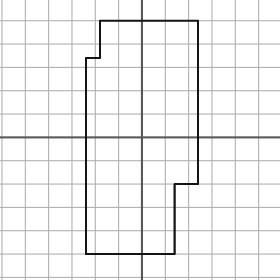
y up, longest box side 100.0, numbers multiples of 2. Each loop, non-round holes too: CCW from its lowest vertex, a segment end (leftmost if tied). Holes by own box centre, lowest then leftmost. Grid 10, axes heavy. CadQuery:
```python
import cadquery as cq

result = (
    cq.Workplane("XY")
    .moveTo(-24.0, -50.0)
    .lineTo(14.0, -50.0)
    .lineTo(14.0, -20.0)
    .lineTo(24.0, -20.0)
    .lineTo(24.0, 50.0)
    .lineTo(-18.0, 50.0)
    .lineTo(-18.0, 34.0)
    .lineTo(-24.0, 34.0)
    .close()
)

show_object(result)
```